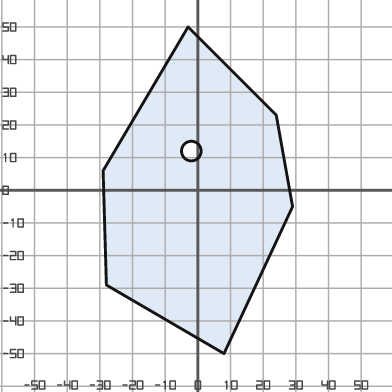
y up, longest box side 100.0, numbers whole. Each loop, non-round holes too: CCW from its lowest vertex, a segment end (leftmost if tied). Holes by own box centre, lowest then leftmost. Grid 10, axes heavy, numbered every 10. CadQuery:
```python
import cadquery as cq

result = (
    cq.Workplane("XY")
    .moveTo(8.0, -50.0)
    .lineTo(29.0, -5.0)
    .lineTo(24.0, 23.0)
    .lineTo(-3.0, 50.0)
    .lineTo(-29.0, 6.0)
    .lineTo(-28.0, -29.0)
    .close()
    .moveTo(-2.0, 12.0)
    .circle(3.0)
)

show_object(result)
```